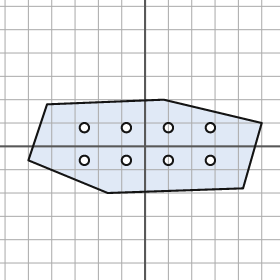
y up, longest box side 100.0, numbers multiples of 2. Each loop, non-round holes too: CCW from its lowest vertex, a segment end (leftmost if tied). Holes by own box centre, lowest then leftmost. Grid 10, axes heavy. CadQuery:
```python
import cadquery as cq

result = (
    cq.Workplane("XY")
    .moveTo(-16.0, -20.0)
    .lineTo(42.0, -18.0)
    .lineTo(50.0, 10.0)
    .lineTo(8.0, 20.0)
    .lineTo(-42.0, 18.0)
    .lineTo(-50.0, -6.0)
    .close()
    .moveTo(-26.0, -6.0)
    .circle(2.0)
    .moveTo(-8.0, -6.0)
    .circle(2.0)
    .moveTo(10.0, -6.0)
    .circle(2.0)
    .moveTo(28.0, -6.0)
    .circle(2.0)
    .moveTo(-26.0, 8.0)
    .circle(2.0)
    .moveTo(-8.0, 8.0)
    .circle(2.0)
    .moveTo(10.0, 8.0)
    .circle(2.0)
    .moveTo(28.0, 8.0)
    .circle(2.0)
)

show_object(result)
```